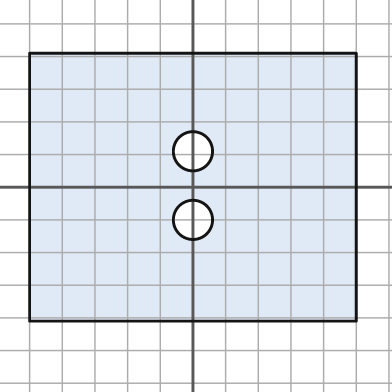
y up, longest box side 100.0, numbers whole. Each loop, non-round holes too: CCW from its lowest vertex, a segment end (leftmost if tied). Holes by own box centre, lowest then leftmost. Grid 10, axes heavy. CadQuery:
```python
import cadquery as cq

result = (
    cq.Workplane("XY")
    .moveTo(-50.0, -41.0)
    .lineTo(50.0, -41.0)
    .lineTo(50.0, 41.0)
    .lineTo(-50.0, 41.0)
    .close()
    .moveTo(0.0, -10.0)
    .circle(6.0)
    .moveTo(0.0, 11.0)
    .circle(6.0)
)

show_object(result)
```